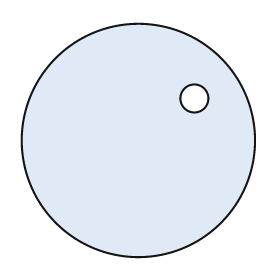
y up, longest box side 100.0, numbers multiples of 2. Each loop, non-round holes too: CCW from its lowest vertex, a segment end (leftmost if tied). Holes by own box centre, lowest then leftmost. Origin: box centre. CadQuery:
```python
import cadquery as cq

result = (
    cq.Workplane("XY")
    .moveTo(0.0, 0.0)
    .circle(50.0)
    .moveTo(24.0, 18.0)
    .circle(6.0)
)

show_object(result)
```